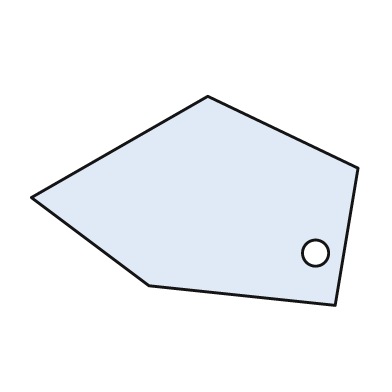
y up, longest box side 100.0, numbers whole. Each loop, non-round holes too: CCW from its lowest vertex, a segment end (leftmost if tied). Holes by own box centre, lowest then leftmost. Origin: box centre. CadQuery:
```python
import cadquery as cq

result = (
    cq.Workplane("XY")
    .moveTo(43.0, -32.0)
    .lineTo(50.0, 10.0)
    .lineTo(4.0, 32.0)
    .lineTo(-50.0, 1.0)
    .lineTo(-14.0, -26.0)
    .close()
    .moveTo(37.0, -16.0)
    .circle(4.0)
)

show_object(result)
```